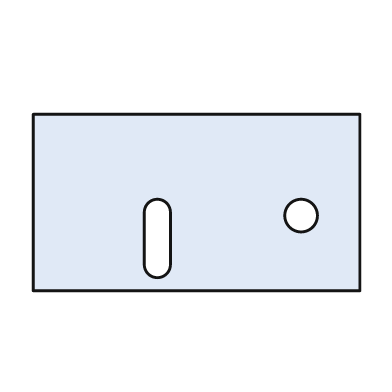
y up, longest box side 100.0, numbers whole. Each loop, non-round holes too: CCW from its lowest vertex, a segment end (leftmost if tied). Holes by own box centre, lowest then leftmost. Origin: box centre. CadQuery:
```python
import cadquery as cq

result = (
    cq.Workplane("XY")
    .moveTo(-50.0, -27.0)
    .lineTo(50.0, -27.0)
    .lineTo(50.0, 27.0)
    .lineTo(-50.0, 27.0)
    .close()
    .moveTo(-16.0, -19.0)
    .threePointArc((-12.0, -23.0), (-8.0, -19.0))
    .lineTo(-8.0, -3.0)
    .threePointArc((-12.0, 1.0), (-16.0, -3.0))
    .close()
    .moveTo(32.0, -4.0)
    .circle(5.0)
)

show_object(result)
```